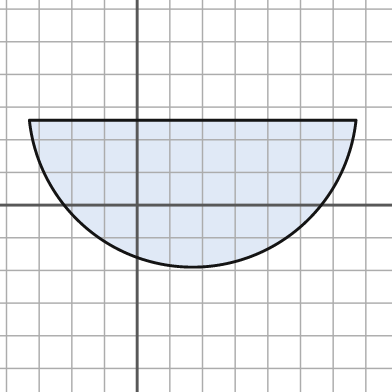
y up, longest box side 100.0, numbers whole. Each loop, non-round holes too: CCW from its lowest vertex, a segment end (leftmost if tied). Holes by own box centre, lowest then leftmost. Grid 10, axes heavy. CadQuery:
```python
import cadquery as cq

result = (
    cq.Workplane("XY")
    .moveTo(-33.0, 26.0)
    .threePointArc((17.0, -19.0), (67.0, 26.0))
    .close()
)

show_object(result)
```